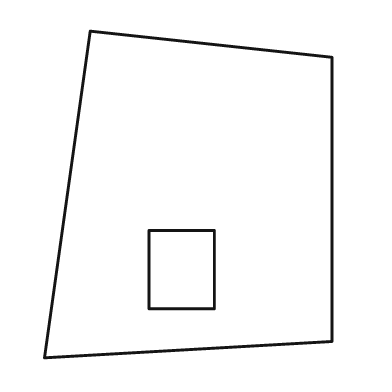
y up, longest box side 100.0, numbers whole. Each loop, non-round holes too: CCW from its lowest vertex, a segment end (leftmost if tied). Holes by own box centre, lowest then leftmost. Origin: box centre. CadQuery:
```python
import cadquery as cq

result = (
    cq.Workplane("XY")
    .moveTo(-44.0, -50.0)
    .lineTo(44.0, -45.0)
    .lineTo(44.0, 42.0)
    .lineTo(-30.0, 50.0)
    .close()
    .moveTo(-12.0, -35.0)
    .lineTo(8.0, -35.0)
    .lineTo(8.0, -11.0)
    .lineTo(-12.0, -11.0)
    .close()
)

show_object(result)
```